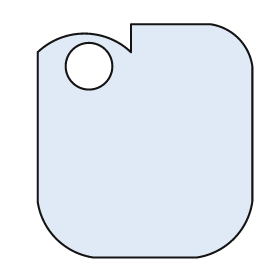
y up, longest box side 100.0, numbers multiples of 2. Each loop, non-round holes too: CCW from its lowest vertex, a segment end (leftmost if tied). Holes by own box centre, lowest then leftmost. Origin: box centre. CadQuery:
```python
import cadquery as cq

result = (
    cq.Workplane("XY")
    .moveTo(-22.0, -50.0)
    .lineTo(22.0, -50.0)
    .threePointArc((38.0, -42.0), (46.0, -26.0))
    .lineTo(46.0, 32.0)
    .threePointArc((40.0, 44.0), (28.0, 50.0))
    .lineTo(-6.0, 50.0)
    .lineTo(-6.0, 38.0)
    .threePointArc((-26.0, 46.0), (-46.0, 38.0))
    .lineTo(-46.0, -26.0)
    .threePointArc((-38.0, -42.0), (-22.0, -50.0))
    .close()
    .moveTo(-24.0, 32.0)
    .circle(10.0)
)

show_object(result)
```